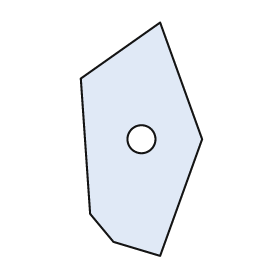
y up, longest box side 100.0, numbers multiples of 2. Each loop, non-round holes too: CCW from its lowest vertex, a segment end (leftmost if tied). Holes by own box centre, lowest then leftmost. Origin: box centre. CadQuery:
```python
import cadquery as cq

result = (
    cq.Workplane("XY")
    .moveTo(8.0, -50.0)
    .lineTo(26.0, 0.0)
    .lineTo(8.0, 50.0)
    .lineTo(-26.0, 26.0)
    .lineTo(-22.0, -32.0)
    .lineTo(-12.0, -44.0)
    .close()
    .moveTo(0.0, 0.0)
    .circle(6.0)
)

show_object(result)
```